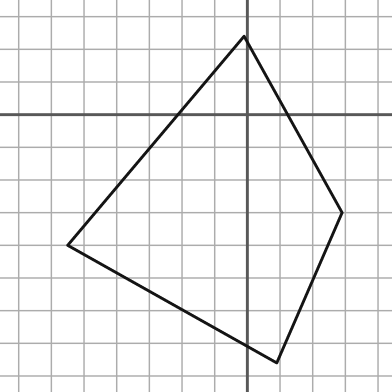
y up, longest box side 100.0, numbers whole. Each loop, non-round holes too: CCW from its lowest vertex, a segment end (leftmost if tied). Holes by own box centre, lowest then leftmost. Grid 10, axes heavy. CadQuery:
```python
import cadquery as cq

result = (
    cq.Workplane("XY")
    .moveTo(9.0, -76.0)
    .lineTo(29.0, -30.0)
    .lineTo(-1.0, 24.0)
    .lineTo(-55.0, -40.0)
    .close()
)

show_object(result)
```